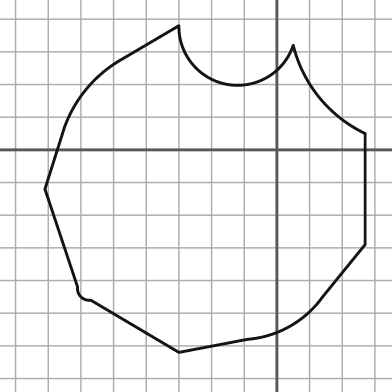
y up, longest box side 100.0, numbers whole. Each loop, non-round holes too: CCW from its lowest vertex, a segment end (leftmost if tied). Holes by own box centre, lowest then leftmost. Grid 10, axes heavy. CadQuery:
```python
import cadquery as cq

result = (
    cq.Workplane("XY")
    .moveTo(-30.0, -62.0)
    .lineTo(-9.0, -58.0)
    .threePointArc((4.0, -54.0), (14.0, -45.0))
    .lineTo(27.0, -29.0)
    .lineTo(27.0, 5.0)
    .threePointArc((13.0, 16.0), (5.0, 32.0))
    .threePointArc((-15.0, 20.0), (-30.0, 38.0))
    .lineTo(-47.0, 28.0)
    .threePointArc((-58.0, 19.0), (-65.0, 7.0))
    .lineTo(-71.0, -12.0)
    .lineTo(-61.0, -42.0)
    .threePointArc((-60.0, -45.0), (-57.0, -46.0))
    .close()
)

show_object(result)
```